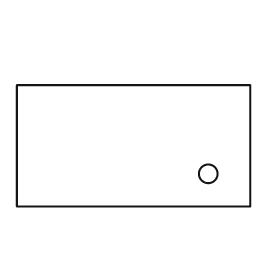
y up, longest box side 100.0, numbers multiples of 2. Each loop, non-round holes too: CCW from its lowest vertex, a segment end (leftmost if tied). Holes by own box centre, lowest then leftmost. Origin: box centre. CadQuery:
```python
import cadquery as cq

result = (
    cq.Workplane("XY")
    .moveTo(-50.0, -26.0)
    .lineTo(50.0, -26.0)
    .lineTo(50.0, 26.0)
    .lineTo(-50.0, 26.0)
    .close()
    .moveTo(32.0, -12.0)
    .circle(4.0)
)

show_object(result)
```